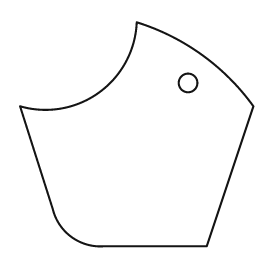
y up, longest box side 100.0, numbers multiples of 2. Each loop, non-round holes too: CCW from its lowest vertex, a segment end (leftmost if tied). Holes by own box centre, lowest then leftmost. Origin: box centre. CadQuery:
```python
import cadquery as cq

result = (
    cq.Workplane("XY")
    .moveTo(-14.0, -48.0)
    .lineTo(30.0, -48.0)
    .lineTo(50.0, 12.0)
    .threePointArc((28.0, 34.0), (0.0, 48.0))
    .threePointArc((-16.0, 18.0), (-50.0, 12.0))
    .lineTo(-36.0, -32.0)
    .threePointArc((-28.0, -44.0), (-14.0, -48.0))
    .close()
    .moveTo(22.0, 22.0)
    .circle(4.0)
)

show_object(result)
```